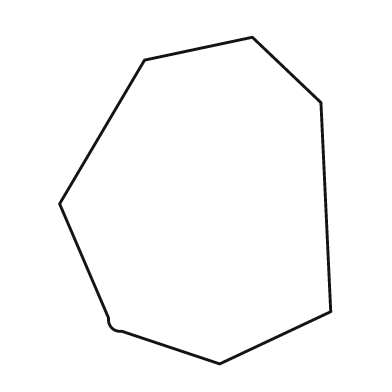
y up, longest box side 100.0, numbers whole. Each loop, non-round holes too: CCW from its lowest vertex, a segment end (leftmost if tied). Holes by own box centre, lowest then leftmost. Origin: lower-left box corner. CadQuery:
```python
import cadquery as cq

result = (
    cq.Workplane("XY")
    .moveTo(49.0, 0.0)
    .lineTo(83.0, 16.0)
    .lineTo(80.0, 80.0)
    .lineTo(59.0, 100.0)
    .lineTo(26.0, 93.0)
    .lineTo(0.0, 49.0)
    .lineTo(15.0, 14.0)
    .threePointArc((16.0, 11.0), (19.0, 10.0))
    .close()
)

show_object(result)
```